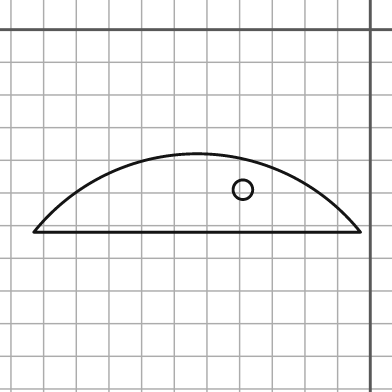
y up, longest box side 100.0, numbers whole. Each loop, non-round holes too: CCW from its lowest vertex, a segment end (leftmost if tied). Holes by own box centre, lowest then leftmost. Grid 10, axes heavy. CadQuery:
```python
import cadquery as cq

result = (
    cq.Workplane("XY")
    .moveTo(-103.0, -62.0)
    .lineTo(-3.0, -62.0)
    .threePointArc((-53.0, -38.0), (-103.0, -62.0))
    .close()
    .moveTo(-39.0, -49.0)
    .circle(3.0)
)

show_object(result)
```